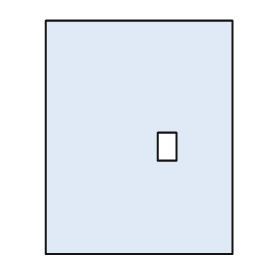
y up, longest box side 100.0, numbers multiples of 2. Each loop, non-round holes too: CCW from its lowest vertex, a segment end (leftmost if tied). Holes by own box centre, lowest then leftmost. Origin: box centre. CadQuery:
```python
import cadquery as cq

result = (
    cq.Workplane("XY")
    .moveTo(-40.0, -50.0)
    .lineTo(40.0, -50.0)
    .lineTo(40.0, 50.0)
    .lineTo(-40.0, 50.0)
    .close()
    .moveTo(8.0, -10.0)
    .lineTo(16.0, -10.0)
    .lineTo(16.0, 2.0)
    .lineTo(8.0, 2.0)
    .close()
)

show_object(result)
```